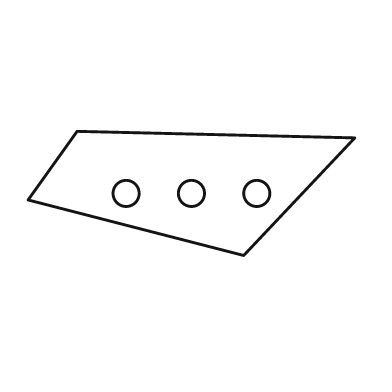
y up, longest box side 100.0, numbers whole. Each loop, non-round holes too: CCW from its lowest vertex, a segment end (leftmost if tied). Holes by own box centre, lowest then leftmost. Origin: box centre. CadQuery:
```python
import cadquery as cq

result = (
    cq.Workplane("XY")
    .moveTo(16.0, -19.0)
    .lineTo(50.0, 17.0)
    .lineTo(-35.0, 19.0)
    .lineTo(-50.0, -2.0)
    .close()
    .moveTo(-20.0, 0.0)
    .circle(4.0)
    .moveTo(0.0, 0.0)
    .circle(4.0)
    .moveTo(20.0, 0.0)
    .circle(4.0)
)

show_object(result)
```